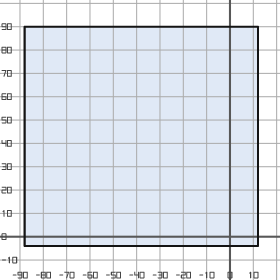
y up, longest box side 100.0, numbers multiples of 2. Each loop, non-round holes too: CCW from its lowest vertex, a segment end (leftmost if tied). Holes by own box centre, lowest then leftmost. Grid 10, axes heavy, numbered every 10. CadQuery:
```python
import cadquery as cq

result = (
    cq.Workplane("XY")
    .moveTo(-88.0, -4.0)
    .lineTo(12.0, -4.0)
    .lineTo(12.0, 90.0)
    .lineTo(-88.0, 90.0)
    .close()
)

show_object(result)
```